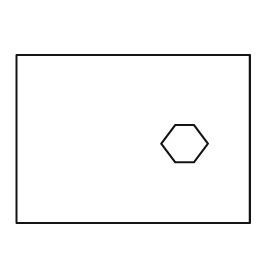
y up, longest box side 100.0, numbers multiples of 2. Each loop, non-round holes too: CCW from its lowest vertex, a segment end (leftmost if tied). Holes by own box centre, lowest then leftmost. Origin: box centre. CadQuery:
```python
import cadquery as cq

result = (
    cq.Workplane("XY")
    .moveTo(-50.0, -36.0)
    .lineTo(50.0, -36.0)
    .lineTo(50.0, 36.0)
    .lineTo(-50.0, 36.0)
    .close()
    .moveTo(18.0, -10.0)
    .lineTo(26.0, -10.0)
    .lineTo(32.0, -2.0)
    .lineTo(26.0, 6.0)
    .lineTo(18.0, 6.0)
    .lineTo(12.0, -2.0)
    .close()
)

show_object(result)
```